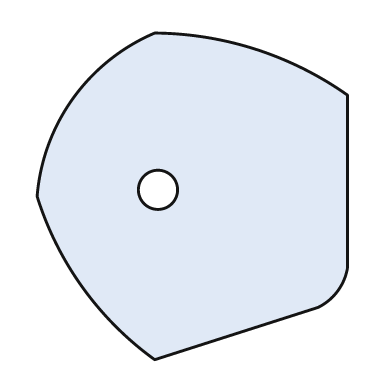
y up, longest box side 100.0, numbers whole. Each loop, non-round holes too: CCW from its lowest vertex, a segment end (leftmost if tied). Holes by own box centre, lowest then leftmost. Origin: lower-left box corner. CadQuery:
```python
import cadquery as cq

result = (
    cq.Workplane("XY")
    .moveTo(36.0, 0.0)
    .lineTo(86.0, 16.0)
    .threePointArc((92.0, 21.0), (95.0, 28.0))
    .lineTo(95.0, 81.0)
    .threePointArc((67.0, 95.0), (36.0, 100.0))
    .threePointArc((11.0, 80.0), (0.0, 50.0))
    .threePointArc((14.0, 22.0), (36.0, 0.0))
    .close()
    .moveTo(37.0, 52.0)
    .circle(6.0)
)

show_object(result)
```